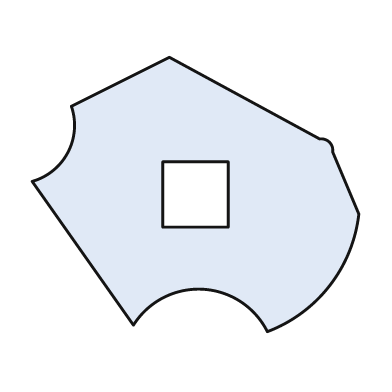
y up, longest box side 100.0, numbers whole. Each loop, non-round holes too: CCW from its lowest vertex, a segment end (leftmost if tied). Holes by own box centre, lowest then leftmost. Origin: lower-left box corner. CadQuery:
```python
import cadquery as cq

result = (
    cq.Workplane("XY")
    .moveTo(72.0, 0.0)
    .threePointArc((91.0, 14.0), (100.0, 36.0))
    .lineTo(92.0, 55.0)
    .threePointArc((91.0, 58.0), (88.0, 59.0))
    .lineTo(42.0, 84.0)
    .lineTo(12.0, 69.0)
    .threePointArc((11.0, 55.0), (0.0, 46.0))
    .lineTo(31.0, 2.0)
    .threePointArc((52.0, 13.0), (72.0, 0.0))
    .close()
    .moveTo(40.0, 32.0)
    .lineTo(60.0, 32.0)
    .lineTo(60.0, 52.0)
    .lineTo(40.0, 52.0)
    .close()
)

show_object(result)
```